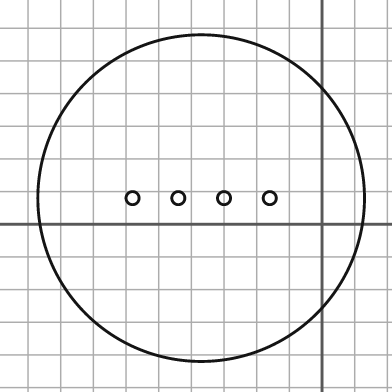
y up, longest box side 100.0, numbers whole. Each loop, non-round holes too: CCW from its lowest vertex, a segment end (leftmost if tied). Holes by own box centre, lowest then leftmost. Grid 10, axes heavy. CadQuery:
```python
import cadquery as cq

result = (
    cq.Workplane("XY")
    .moveTo(-37.0, 8.0)
    .circle(50.0)
    .moveTo(-58.0, 8.0)
    .circle(2.0)
    .moveTo(-44.0, 8.0)
    .circle(2.0)
    .moveTo(-30.0, 8.0)
    .circle(2.0)
    .moveTo(-16.0, 8.0)
    .circle(2.0)
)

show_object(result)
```